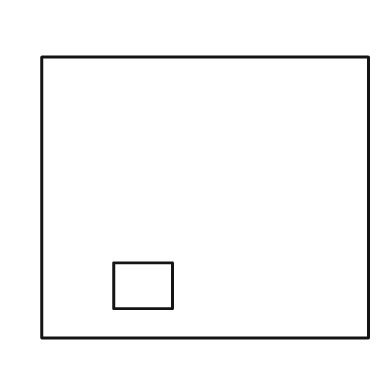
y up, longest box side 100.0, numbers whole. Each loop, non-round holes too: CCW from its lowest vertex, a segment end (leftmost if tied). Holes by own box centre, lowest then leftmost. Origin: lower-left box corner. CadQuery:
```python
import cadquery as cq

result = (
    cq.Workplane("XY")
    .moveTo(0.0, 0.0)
    .lineTo(100.0, 0.0)
    .lineTo(100.0, 86.0)
    .lineTo(0.0, 86.0)
    .close()
    .moveTo(22.0, 9.0)
    .lineTo(40.0, 9.0)
    .lineTo(40.0, 23.0)
    .lineTo(22.0, 23.0)
    .close()
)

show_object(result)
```